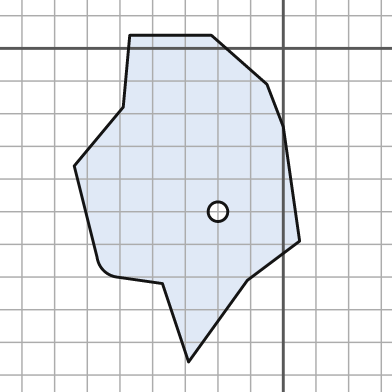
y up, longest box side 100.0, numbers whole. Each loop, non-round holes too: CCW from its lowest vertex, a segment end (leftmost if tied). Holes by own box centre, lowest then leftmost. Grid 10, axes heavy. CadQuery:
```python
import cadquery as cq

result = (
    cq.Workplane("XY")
    .moveTo(-29.0, -96.0)
    .lineTo(-11.0, -71.0)
    .lineTo(5.0, -59.0)
    .lineTo(0.0, -24.0)
    .lineTo(-5.0, -11.0)
    .lineTo(-22.0, 4.0)
    .lineTo(-47.0, 4.0)
    .lineTo(-49.0, -18.0)
    .lineTo(-64.0, -36.0)
    .lineTo(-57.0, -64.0)
    .threePointArc((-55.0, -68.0), (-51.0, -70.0))
    .lineTo(-37.0, -72.0)
    .close()
    .moveTo(-20.0, -50.0)
    .circle(3.0)
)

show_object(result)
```